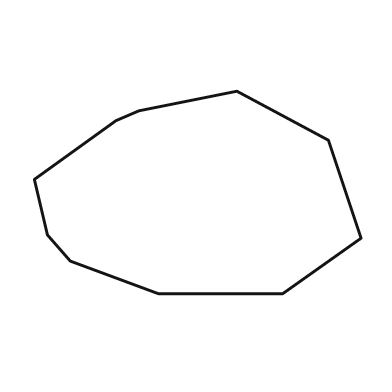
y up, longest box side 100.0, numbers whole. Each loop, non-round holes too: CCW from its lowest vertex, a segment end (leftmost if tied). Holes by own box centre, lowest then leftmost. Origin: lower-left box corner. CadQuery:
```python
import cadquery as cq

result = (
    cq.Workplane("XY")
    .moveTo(38.0, 0.0)
    .lineTo(76.0, 0.0)
    .lineTo(100.0, 17.0)
    .lineTo(90.0, 47.0)
    .lineTo(62.0, 62.0)
    .lineTo(32.0, 56.0)
    .lineTo(25.0, 53.0)
    .lineTo(0.0, 35.0)
    .lineTo(4.0, 18.0)
    .lineTo(11.0, 10.0)
    .close()
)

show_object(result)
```